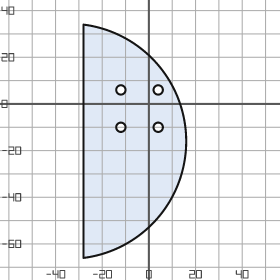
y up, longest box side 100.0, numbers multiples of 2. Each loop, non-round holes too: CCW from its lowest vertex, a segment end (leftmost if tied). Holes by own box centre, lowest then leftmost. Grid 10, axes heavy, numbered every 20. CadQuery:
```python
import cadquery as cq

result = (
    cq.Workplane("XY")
    .moveTo(-28.0, -66.0)
    .threePointArc((16.0, -16.0), (-28.0, 34.0))
    .close()
    .moveTo(-12.0, -10.0)
    .circle(2.0)
    .moveTo(4.0, -10.0)
    .circle(2.0)
    .moveTo(-12.0, 6.0)
    .circle(2.0)
    .moveTo(4.0, 6.0)
    .circle(2.0)
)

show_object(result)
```